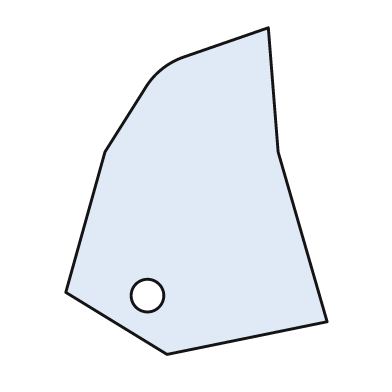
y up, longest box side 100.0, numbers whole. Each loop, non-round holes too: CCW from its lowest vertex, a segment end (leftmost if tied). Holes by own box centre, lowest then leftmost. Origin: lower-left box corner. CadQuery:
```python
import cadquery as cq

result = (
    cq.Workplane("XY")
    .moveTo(31.0, 0.0)
    .lineTo(80.0, 10.0)
    .lineTo(65.0, 62.0)
    .lineTo(62.0, 100.0)
    .lineTo(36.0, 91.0)
    .threePointArc((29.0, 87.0), (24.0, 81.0))
    .lineTo(12.0, 62.0)
    .lineTo(0.0, 19.0)
    .close()
    .moveTo(25.0, 18.0)
    .circle(5.0)
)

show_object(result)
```